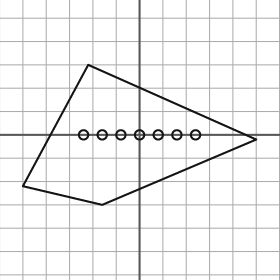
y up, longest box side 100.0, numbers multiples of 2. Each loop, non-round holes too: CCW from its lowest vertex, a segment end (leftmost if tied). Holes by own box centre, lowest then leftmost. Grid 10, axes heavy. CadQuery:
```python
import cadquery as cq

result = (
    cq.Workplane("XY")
    .moveTo(-16.0, -30.0)
    .lineTo(50.0, -2.0)
    .lineTo(-22.0, 30.0)
    .lineTo(-50.0, -22.0)
    .close()
    .moveTo(-24.0, 0.0)
    .circle(2.0)
    .moveTo(-16.0, 0.0)
    .circle(2.0)
    .moveTo(-8.0, 0.0)
    .circle(2.0)
    .moveTo(0.0, 0.0)
    .circle(2.0)
    .moveTo(8.0, 0.0)
    .circle(2.0)
    .moveTo(16.0, 0.0)
    .circle(2.0)
    .moveTo(24.0, 0.0)
    .circle(2.0)
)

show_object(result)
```